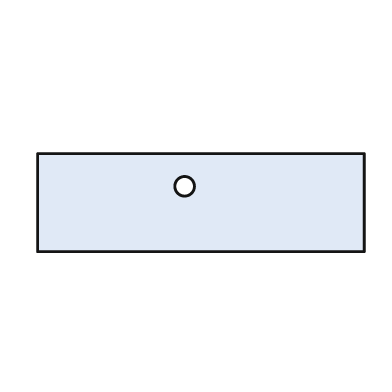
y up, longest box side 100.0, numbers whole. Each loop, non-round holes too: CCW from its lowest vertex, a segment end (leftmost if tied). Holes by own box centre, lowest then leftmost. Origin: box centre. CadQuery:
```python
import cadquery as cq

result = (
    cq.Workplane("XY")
    .moveTo(-50.0, -15.0)
    .lineTo(50.0, -15.0)
    .lineTo(50.0, 15.0)
    .lineTo(-50.0, 15.0)
    .close()
    .moveTo(-5.0, 5.0)
    .circle(3.0)
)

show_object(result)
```